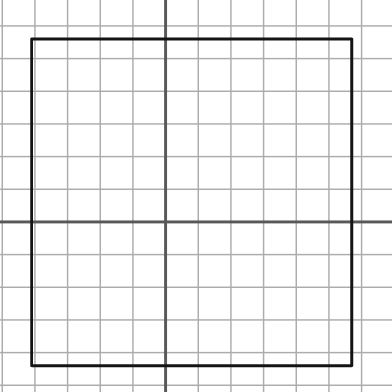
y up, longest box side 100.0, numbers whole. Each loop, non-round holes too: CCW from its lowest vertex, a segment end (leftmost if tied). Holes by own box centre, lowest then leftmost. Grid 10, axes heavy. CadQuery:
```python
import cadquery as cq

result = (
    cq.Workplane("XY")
    .moveTo(-41.0, -44.0)
    .lineTo(57.0, -44.0)
    .lineTo(57.0, 56.0)
    .lineTo(-41.0, 56.0)
    .close()
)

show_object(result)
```